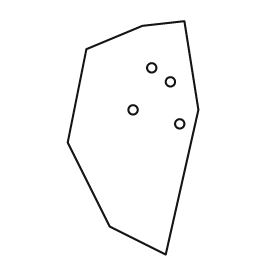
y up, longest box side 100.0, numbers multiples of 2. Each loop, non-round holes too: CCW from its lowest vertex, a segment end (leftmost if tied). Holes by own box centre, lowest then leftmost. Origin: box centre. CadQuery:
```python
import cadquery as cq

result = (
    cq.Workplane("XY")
    .moveTo(14.0, -50.0)
    .lineTo(28.0, 12.0)
    .lineTo(22.0, 50.0)
    .lineTo(4.0, 48.0)
    .lineTo(-20.0, 38.0)
    .lineTo(-28.0, -2.0)
    .lineTo(-10.0, -38.0)
    .close()
    .moveTo(20.0, 6.0)
    .circle(2.0)
    .moveTo(0.0, 12.0)
    .circle(2.0)
    .moveTo(16.0, 24.0)
    .circle(2.0)
    .moveTo(8.0, 30.0)
    .circle(2.0)
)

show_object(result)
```